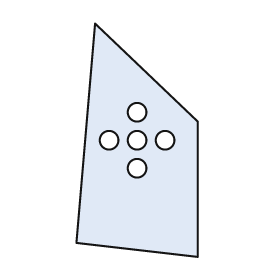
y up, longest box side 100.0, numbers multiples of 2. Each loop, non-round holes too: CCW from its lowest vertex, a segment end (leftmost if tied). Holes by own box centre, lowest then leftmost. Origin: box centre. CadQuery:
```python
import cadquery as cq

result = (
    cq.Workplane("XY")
    .moveTo(26.0, -50.0)
    .lineTo(26.0, 8.0)
    .lineTo(-18.0, 50.0)
    .lineTo(-26.0, -44.0)
    .close()
    .moveTo(0.0, -12.0)
    .circle(4.0)
    .moveTo(-12.0, 0.0)
    .circle(4.0)
    .moveTo(0.0, 0.0)
    .circle(4.0)
    .moveTo(12.0, 0.0)
    .circle(4.0)
    .moveTo(0.0, 12.0)
    .circle(4.0)
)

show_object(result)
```